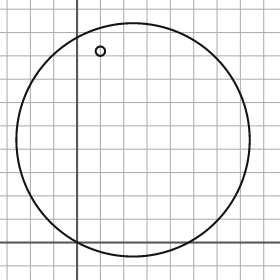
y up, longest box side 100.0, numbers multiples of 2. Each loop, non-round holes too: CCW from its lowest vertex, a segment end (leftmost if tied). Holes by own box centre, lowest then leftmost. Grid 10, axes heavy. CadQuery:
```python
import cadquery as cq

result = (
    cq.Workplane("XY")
    .moveTo(24.0, 44.0)
    .circle(50.0)
    .moveTo(10.0, 82.0)
    .circle(2.0)
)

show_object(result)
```